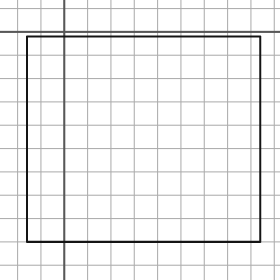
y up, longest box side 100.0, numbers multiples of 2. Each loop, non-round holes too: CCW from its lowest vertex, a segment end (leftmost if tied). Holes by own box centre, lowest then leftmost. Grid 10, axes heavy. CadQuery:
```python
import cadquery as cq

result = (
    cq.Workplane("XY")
    .moveTo(-16.0, -90.0)
    .lineTo(84.0, -90.0)
    .lineTo(84.0, -2.0)
    .lineTo(-16.0, -2.0)
    .close()
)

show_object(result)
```